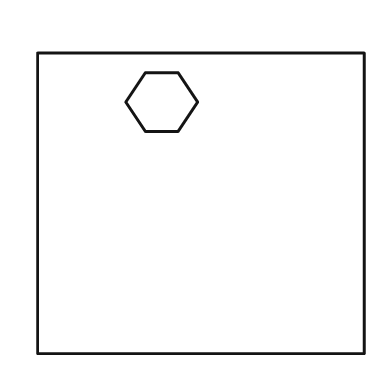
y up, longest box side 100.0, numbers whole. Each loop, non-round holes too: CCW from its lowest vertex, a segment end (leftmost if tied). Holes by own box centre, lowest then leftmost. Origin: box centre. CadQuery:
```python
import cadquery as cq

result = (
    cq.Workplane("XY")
    .moveTo(-50.0, -46.0)
    .lineTo(50.0, -46.0)
    .lineTo(50.0, 46.0)
    .lineTo(-50.0, 46.0)
    .close()
    .moveTo(-17.0, 22.0)
    .lineTo(-7.0, 22.0)
    .lineTo(-1.0, 31.0)
    .lineTo(-7.0, 40.0)
    .lineTo(-17.0, 40.0)
    .lineTo(-23.0, 31.0)
    .close()
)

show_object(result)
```